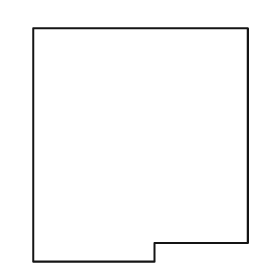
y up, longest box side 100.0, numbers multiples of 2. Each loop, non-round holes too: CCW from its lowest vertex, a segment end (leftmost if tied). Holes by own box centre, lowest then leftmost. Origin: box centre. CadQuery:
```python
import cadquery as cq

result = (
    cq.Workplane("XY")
    .moveTo(-46.0, -50.0)
    .lineTo(6.0, -50.0)
    .lineTo(6.0, -42.0)
    .lineTo(46.0, -42.0)
    .lineTo(46.0, 50.0)
    .lineTo(-46.0, 50.0)
    .close()
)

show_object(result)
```